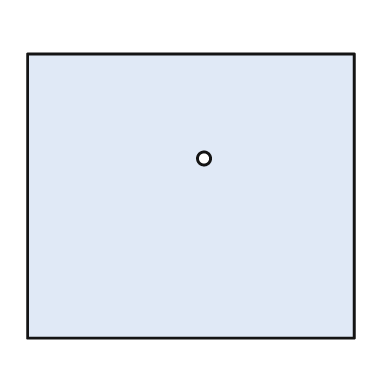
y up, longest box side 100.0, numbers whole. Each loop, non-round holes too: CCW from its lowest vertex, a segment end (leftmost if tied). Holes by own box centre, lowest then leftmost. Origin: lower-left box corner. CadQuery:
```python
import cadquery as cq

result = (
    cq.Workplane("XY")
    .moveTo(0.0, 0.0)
    .lineTo(100.0, 0.0)
    .lineTo(100.0, 87.0)
    .lineTo(0.0, 87.0)
    .close()
    .moveTo(54.0, 55.0)
    .circle(2.0)
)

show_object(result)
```